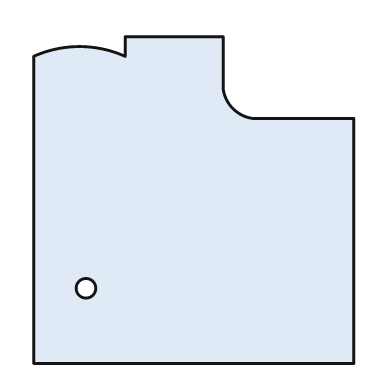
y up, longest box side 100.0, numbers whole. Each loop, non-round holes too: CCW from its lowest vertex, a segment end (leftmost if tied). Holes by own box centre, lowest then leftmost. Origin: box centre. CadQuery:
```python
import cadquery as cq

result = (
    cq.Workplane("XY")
    .moveTo(-49.0, -50.0)
    .lineTo(49.0, -50.0)
    .lineTo(49.0, 25.0)
    .lineTo(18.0, 25.0)
    .threePointArc((12.0, 28.0), (9.0, 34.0))
    .lineTo(9.0, 50.0)
    .lineTo(-21.0, 50.0)
    .lineTo(-21.0, 44.0)
    .threePointArc((-35.0, 47.0), (-49.0, 44.0))
    .close()
    .moveTo(-33.0, -27.0)
    .circle(3.0)
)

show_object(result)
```